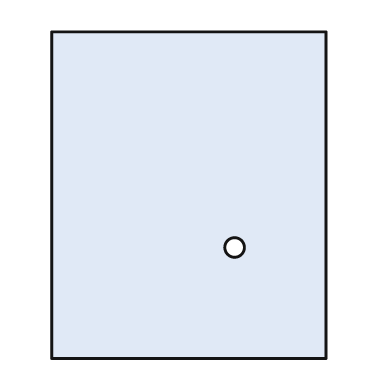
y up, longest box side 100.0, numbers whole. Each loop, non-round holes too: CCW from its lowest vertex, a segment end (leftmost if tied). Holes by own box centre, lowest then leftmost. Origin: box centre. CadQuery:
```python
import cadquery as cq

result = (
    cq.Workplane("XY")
    .moveTo(-42.0, -50.0)
    .lineTo(42.0, -50.0)
    .lineTo(42.0, 50.0)
    .lineTo(-42.0, 50.0)
    .close()
    .moveTo(14.0, -16.0)
    .circle(3.0)
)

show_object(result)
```